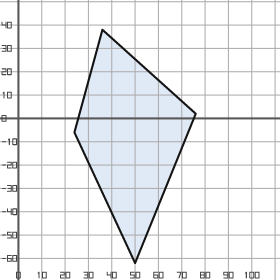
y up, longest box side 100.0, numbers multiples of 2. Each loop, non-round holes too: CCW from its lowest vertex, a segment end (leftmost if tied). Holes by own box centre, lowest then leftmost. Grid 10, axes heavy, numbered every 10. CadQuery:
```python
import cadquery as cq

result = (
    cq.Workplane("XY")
    .moveTo(50.0, -62.0)
    .lineTo(76.0, 2.0)
    .lineTo(36.0, 38.0)
    .lineTo(24.0, -6.0)
    .close()
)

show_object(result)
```